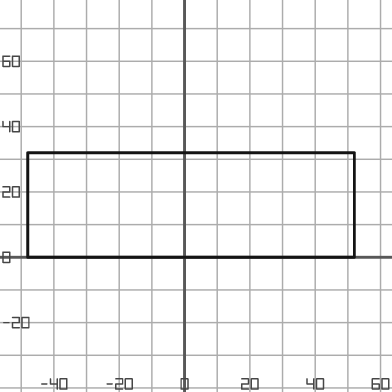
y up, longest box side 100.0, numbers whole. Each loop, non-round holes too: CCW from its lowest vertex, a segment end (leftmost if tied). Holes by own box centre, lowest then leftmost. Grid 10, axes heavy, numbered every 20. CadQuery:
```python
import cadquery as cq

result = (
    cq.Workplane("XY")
    .moveTo(-48.0, 0.0)
    .lineTo(52.0, 0.0)
    .lineTo(52.0, 32.0)
    .lineTo(-48.0, 32.0)
    .close()
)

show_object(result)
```